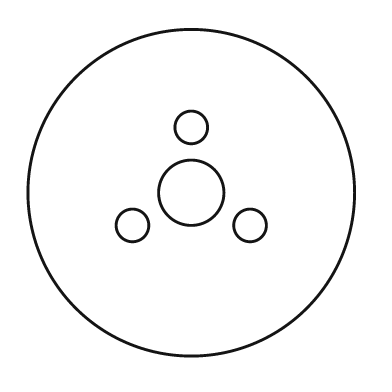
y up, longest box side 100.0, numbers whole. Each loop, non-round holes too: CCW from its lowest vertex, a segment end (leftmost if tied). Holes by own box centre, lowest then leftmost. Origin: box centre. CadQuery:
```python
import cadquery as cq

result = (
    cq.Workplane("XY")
    .moveTo(0.0, 0.0)
    .circle(50.0)
    .moveTo(-18.0, -10.0)
    .circle(5.0)
    .moveTo(18.0, -10.0)
    .circle(5.0)
    .moveTo(0.0, 0.0)
    .circle(10.0)
    .moveTo(0.0, 20.0)
    .circle(5.0)
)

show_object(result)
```